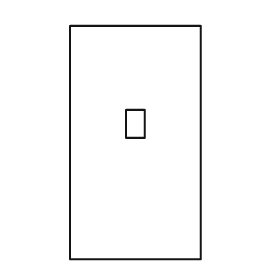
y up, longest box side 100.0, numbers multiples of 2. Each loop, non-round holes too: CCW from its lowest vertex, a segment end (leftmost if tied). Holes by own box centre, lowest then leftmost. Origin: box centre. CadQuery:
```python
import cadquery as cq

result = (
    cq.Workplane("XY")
    .moveTo(-28.0, -50.0)
    .lineTo(28.0, -50.0)
    .lineTo(28.0, 50.0)
    .lineTo(-28.0, 50.0)
    .close()
    .moveTo(-4.0, 2.0)
    .lineTo(4.0, 2.0)
    .lineTo(4.0, 14.0)
    .lineTo(-4.0, 14.0)
    .close()
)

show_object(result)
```